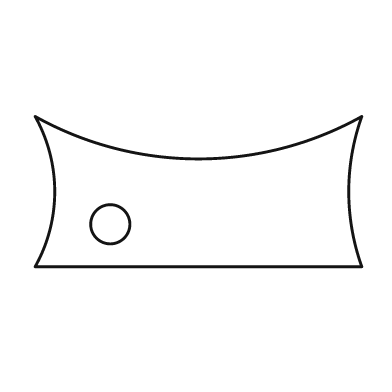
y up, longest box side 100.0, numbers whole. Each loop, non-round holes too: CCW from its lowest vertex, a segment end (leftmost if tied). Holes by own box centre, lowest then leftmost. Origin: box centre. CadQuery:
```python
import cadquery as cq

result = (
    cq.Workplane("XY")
    .moveTo(-50.0, -23.0)
    .lineTo(50.0, -23.0)
    .threePointArc((46.0, 0.0), (50.0, 23.0))
    .threePointArc((0.0, 10.0), (-50.0, 23.0))
    .threePointArc((-44.0, 0.0), (-50.0, -23.0))
    .close()
    .moveTo(-27.0, -10.0)
    .circle(6.0)
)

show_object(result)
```